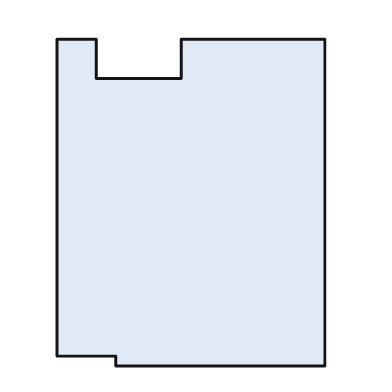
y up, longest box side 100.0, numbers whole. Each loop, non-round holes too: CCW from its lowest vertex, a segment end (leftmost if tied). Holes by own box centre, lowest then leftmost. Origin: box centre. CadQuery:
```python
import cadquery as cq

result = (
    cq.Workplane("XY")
    .moveTo(-23.0, -50.0)
    .lineTo(41.0, -50.0)
    .lineTo(41.0, 50.0)
    .lineTo(-3.0, 50.0)
    .lineTo(-3.0, 38.0)
    .lineTo(-29.0, 38.0)
    .lineTo(-29.0, 50.0)
    .lineTo(-41.0, 50.0)
    .lineTo(-41.0, -47.0)
    .lineTo(-23.0, -47.0)
    .close()
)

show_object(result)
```